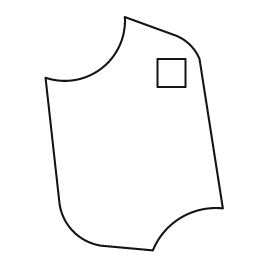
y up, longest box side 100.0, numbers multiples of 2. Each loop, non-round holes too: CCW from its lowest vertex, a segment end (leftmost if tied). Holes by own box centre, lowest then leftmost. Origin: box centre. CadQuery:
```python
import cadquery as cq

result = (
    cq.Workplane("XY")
    .moveTo(8.0, -50.0)
    .threePointArc((20.0, -36.0), (38.0, -32.0))
    .lineTo(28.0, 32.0)
    .threePointArc((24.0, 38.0), (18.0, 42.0))
    .lineTo(-4.0, 50.0)
    .threePointArc((-14.0, 28.0), (-38.0, 24.0))
    .lineTo(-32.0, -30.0)
    .threePointArc((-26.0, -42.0), (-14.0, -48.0))
    .close()
    .moveTo(10.0, 20.0)
    .lineTo(22.0, 20.0)
    .lineTo(22.0, 32.0)
    .lineTo(10.0, 32.0)
    .close()
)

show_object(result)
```